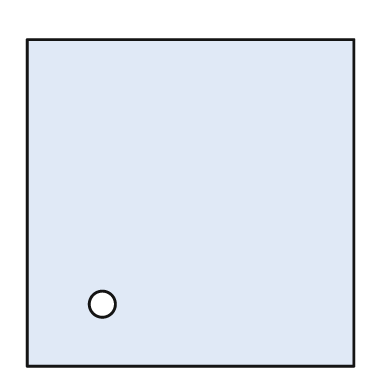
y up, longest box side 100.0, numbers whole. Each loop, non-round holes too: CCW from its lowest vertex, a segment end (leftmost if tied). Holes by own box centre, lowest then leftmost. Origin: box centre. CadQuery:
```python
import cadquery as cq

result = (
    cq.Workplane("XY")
    .moveTo(-50.0, -50.0)
    .lineTo(50.0, -50.0)
    .lineTo(50.0, 50.0)
    .lineTo(-50.0, 50.0)
    .close()
    .moveTo(-27.0, -31.0)
    .circle(4.0)
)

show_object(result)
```